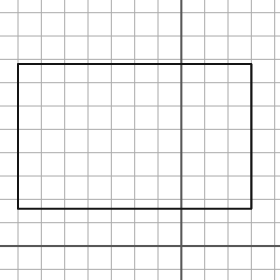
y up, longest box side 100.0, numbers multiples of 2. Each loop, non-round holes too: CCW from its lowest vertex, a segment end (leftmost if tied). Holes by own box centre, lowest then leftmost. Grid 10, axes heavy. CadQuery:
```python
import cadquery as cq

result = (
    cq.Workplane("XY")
    .moveTo(-70.0, 16.0)
    .lineTo(30.0, 16.0)
    .lineTo(30.0, 78.0)
    .lineTo(-70.0, 78.0)
    .close()
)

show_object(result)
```